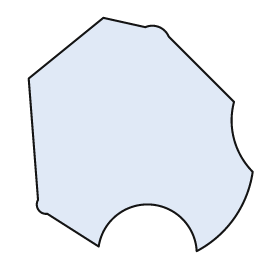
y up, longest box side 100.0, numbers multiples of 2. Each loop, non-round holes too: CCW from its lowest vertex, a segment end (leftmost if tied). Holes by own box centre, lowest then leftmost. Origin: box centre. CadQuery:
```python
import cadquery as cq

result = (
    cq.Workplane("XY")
    .moveTo(24.0, -50.0)
    .threePointArc((40.0, -36.0), (48.0, -16.0))
    .threePointArc((40.0, -2.0), (40.0, 14.0))
    .lineTo(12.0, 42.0)
    .threePointArc((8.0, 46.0), (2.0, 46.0))
    .lineTo(-16.0, 50.0)
    .lineTo(-48.0, 24.0)
    .lineTo(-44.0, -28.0)
    .threePointArc((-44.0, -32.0), (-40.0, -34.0))
    .lineTo(-18.0, -48.0)
    .threePointArc((4.0, -30.0), (24.0, -50.0))
    .close()
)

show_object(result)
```